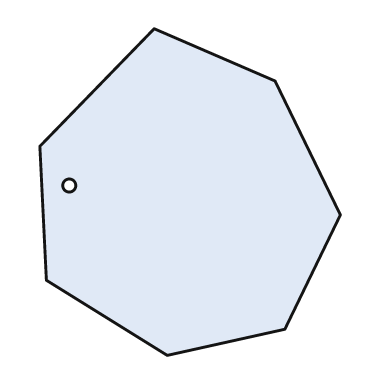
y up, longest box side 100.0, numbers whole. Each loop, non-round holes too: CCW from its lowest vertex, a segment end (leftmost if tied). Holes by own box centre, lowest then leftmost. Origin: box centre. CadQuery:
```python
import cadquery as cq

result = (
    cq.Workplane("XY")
    .moveTo(-7.0, -50.0)
    .lineTo(29.0, -42.0)
    .lineTo(46.0, -7.0)
    .lineTo(26.0, 34.0)
    .lineTo(-11.0, 50.0)
    .lineTo(-46.0, 14.0)
    .lineTo(-44.0, -27.0)
    .close()
    .moveTo(-37.0, 2.0)
    .circle(2.0)
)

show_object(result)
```